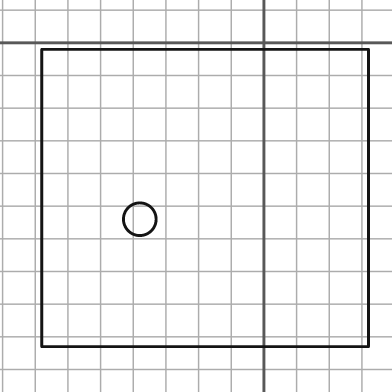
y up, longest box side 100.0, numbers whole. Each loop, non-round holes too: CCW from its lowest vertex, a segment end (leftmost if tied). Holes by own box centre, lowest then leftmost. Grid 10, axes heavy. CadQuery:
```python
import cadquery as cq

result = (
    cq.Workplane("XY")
    .moveTo(-68.0, -93.0)
    .lineTo(32.0, -93.0)
    .lineTo(32.0, -2.0)
    .lineTo(-68.0, -2.0)
    .close()
    .moveTo(-38.0, -54.0)
    .circle(5.0)
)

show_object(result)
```